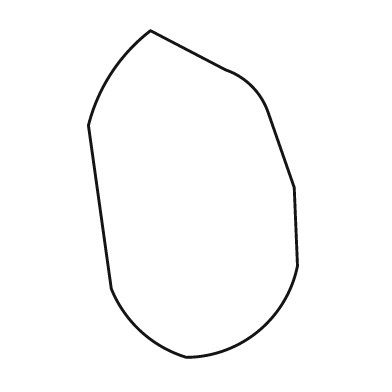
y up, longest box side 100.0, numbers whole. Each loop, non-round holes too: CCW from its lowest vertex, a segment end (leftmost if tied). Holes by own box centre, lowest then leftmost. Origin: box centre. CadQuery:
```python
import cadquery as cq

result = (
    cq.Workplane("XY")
    .moveTo(-2.0, -50.0)
    .threePointArc((20.0, -42.0), (32.0, -22.0))
    .lineTo(31.0, 2.0)
    .lineTo(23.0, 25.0)
    .threePointArc((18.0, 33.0), (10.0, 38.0))
    .lineTo(-13.0, 50.0)
    .threePointArc((-25.0, 37.0), (-32.0, 21.0))
    .lineTo(-25.0, -29.0)
    .threePointArc((-16.0, -42.0), (-2.0, -50.0))
    .close()
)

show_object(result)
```